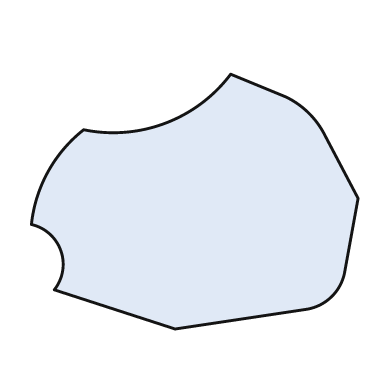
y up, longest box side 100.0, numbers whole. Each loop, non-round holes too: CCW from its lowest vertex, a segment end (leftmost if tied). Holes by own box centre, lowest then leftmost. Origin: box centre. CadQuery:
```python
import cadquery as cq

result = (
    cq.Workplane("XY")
    .moveTo(-6.0, -39.0)
    .lineTo(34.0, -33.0)
    .threePointArc((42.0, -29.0), (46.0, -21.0))
    .lineTo(50.0, 1.0)
    .lineTo(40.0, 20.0)
    .threePointArc((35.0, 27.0), (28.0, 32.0))
    .lineTo(11.0, 39.0)
    .threePointArc((-9.0, 24.0), (-34.0, 22.0))
    .threePointArc((-45.0, 9.0), (-50.0, -7.0))
    .threePointArc((-41.0, -15.0), (-43.0, -27.0))
    .close()
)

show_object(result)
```